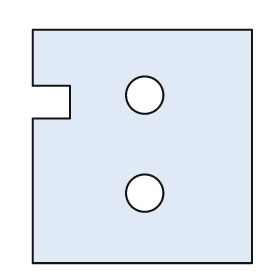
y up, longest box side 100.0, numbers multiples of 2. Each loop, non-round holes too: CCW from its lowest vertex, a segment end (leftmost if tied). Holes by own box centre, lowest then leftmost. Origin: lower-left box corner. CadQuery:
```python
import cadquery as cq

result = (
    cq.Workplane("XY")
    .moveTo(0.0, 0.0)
    .lineTo(94.0, 0.0)
    .lineTo(94.0, 100.0)
    .lineTo(0.0, 100.0)
    .lineTo(0.0, 76.0)
    .lineTo(16.0, 76.0)
    .lineTo(16.0, 62.0)
    .lineTo(0.0, 62.0)
    .close()
    .moveTo(48.0, 30.0)
    .circle(8.0)
    .moveTo(48.0, 72.0)
    .circle(8.0)
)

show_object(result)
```